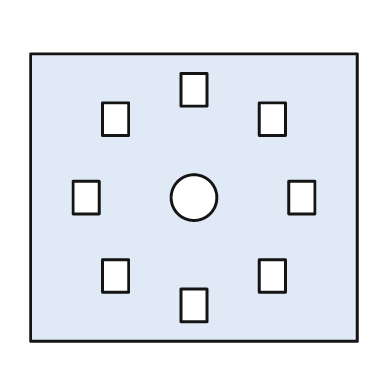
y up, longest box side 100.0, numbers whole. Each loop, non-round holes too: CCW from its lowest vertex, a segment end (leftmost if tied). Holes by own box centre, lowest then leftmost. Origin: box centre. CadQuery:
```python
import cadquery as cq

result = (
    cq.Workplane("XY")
    .moveTo(-50.0, -44.0)
    .lineTo(50.0, -44.0)
    .lineTo(50.0, 44.0)
    .lineTo(-50.0, 44.0)
    .close()
    .moveTo(-4.0, -38.0)
    .lineTo(4.0, -38.0)
    .lineTo(4.0, -28.0)
    .lineTo(-4.0, -28.0)
    .close()
    .moveTo(-28.0, -29.0)
    .lineTo(-20.0, -29.0)
    .lineTo(-20.0, -19.0)
    .lineTo(-28.0, -19.0)
    .close()
    .moveTo(20.0, -29.0)
    .lineTo(28.0, -29.0)
    .lineTo(28.0, -19.0)
    .lineTo(20.0, -19.0)
    .close()
    .moveTo(-37.0, -5.0)
    .lineTo(-29.0, -5.0)
    .lineTo(-29.0, 5.0)
    .lineTo(-37.0, 5.0)
    .close()
    .moveTo(0.0, 0.0)
    .circle(7.0)
    .moveTo(29.0, -5.0)
    .lineTo(37.0, -5.0)
    .lineTo(37.0, 5.0)
    .lineTo(29.0, 5.0)
    .close()
    .moveTo(-28.0, 19.0)
    .lineTo(-20.0, 19.0)
    .lineTo(-20.0, 29.0)
    .lineTo(-28.0, 29.0)
    .close()
    .moveTo(20.0, 19.0)
    .lineTo(28.0, 19.0)
    .lineTo(28.0, 29.0)
    .lineTo(20.0, 29.0)
    .close()
    .moveTo(-4.0, 28.0)
    .lineTo(4.0, 28.0)
    .lineTo(4.0, 38.0)
    .lineTo(-4.0, 38.0)
    .close()
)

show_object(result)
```